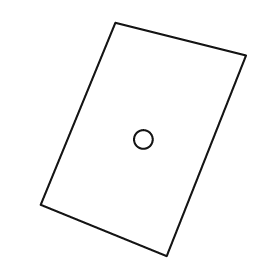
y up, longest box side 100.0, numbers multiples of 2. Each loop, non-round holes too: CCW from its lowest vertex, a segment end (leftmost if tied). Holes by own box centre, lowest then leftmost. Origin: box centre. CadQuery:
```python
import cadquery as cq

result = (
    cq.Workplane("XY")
    .moveTo(10.0, -50.0)
    .lineTo(44.0, 36.0)
    .lineTo(-12.0, 50.0)
    .lineTo(-44.0, -28.0)
    .close()
    .moveTo(0.0, 0.0)
    .circle(4.0)
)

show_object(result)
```